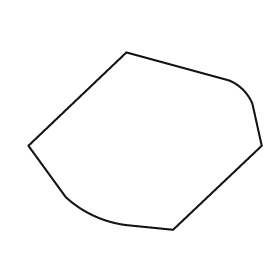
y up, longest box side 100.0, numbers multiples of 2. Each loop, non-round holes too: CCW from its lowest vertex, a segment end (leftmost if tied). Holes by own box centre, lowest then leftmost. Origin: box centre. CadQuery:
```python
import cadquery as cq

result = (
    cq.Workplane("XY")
    .moveTo(12.0, -38.0)
    .lineTo(50.0, -2.0)
    .lineTo(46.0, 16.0)
    .threePointArc((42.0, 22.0), (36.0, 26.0))
    .lineTo(-8.0, 38.0)
    .lineTo(-50.0, -2.0)
    .lineTo(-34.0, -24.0)
    .threePointArc((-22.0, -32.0), (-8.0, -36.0))
    .close()
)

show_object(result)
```